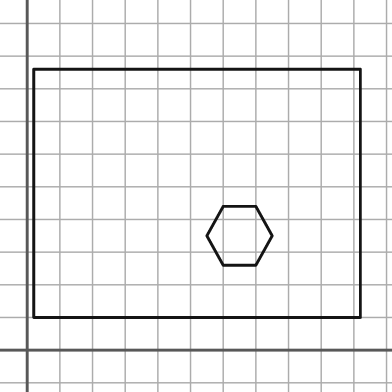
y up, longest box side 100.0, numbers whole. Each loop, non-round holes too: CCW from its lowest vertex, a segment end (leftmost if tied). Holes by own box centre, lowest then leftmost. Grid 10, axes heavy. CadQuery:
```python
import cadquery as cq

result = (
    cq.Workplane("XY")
    .moveTo(2.0, 10.0)
    .lineTo(102.0, 10.0)
    .lineTo(102.0, 86.0)
    .lineTo(2.0, 86.0)
    .close()
    .moveTo(60.0, 26.0)
    .lineTo(70.0, 26.0)
    .lineTo(75.0, 35.0)
    .lineTo(70.0, 44.0)
    .lineTo(60.0, 44.0)
    .lineTo(55.0, 35.0)
    .close()
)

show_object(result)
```